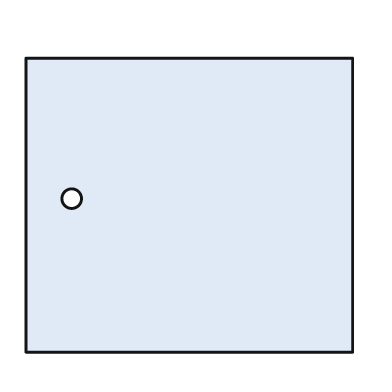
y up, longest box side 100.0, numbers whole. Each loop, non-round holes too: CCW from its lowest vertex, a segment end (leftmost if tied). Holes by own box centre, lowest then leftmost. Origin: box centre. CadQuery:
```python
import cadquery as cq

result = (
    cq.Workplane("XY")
    .moveTo(-50.0, -45.0)
    .lineTo(50.0, -45.0)
    .lineTo(50.0, 45.0)
    .lineTo(-50.0, 45.0)
    .close()
    .moveTo(-36.0, 2.0)
    .circle(3.0)
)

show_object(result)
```